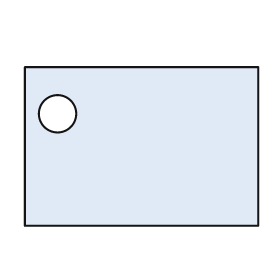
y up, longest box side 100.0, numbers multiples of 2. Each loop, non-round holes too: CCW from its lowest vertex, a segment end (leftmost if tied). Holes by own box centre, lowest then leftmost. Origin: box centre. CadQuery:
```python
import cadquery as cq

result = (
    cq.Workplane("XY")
    .moveTo(-50.0, -34.0)
    .lineTo(50.0, -34.0)
    .lineTo(50.0, 34.0)
    .lineTo(-50.0, 34.0)
    .close()
    .moveTo(-36.0, 14.0)
    .circle(8.0)
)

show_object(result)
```